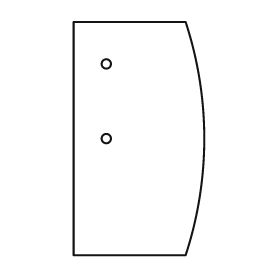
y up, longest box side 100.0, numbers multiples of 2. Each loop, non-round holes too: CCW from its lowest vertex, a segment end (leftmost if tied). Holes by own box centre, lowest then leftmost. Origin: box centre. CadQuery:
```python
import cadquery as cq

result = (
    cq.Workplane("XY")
    .moveTo(-28.0, -50.0)
    .lineTo(20.0, -50.0)
    .threePointArc((28.0, 0.0), (20.0, 50.0))
    .lineTo(-28.0, 50.0)
    .close()
    .moveTo(-14.0, 0.0)
    .circle(2.0)
    .moveTo(-14.0, 32.0)
    .circle(2.0)
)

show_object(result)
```